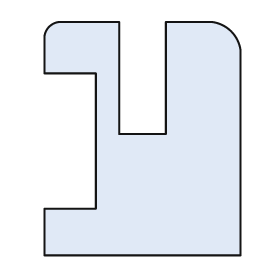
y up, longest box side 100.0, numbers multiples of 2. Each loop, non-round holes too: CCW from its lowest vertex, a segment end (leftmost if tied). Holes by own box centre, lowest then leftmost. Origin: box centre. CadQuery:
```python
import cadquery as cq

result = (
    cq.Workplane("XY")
    .moveTo(-42.0, -50.0)
    .lineTo(42.0, -50.0)
    .lineTo(42.0, 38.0)
    .threePointArc((38.0, 46.0), (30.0, 50.0))
    .lineTo(10.0, 50.0)
    .lineTo(10.0, 2.0)
    .lineTo(-10.0, 2.0)
    .lineTo(-10.0, 50.0)
    .lineTo(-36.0, 50.0)
    .threePointArc((-40.0, 48.0), (-42.0, 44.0))
    .lineTo(-42.0, 28.0)
    .lineTo(-20.0, 28.0)
    .lineTo(-20.0, -30.0)
    .lineTo(-42.0, -30.0)
    .close()
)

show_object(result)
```